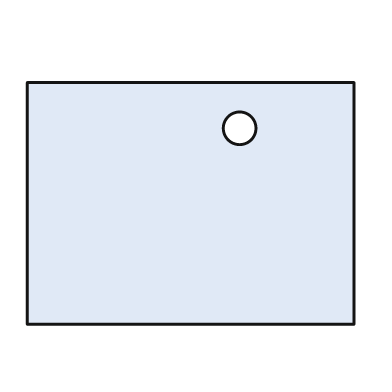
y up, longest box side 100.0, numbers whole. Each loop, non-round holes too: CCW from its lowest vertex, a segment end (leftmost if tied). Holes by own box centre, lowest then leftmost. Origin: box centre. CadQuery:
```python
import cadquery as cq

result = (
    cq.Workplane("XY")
    .moveTo(-50.0, -37.0)
    .lineTo(50.0, -37.0)
    .lineTo(50.0, 37.0)
    .lineTo(-50.0, 37.0)
    .close()
    .moveTo(15.0, 23.0)
    .circle(5.0)
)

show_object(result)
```